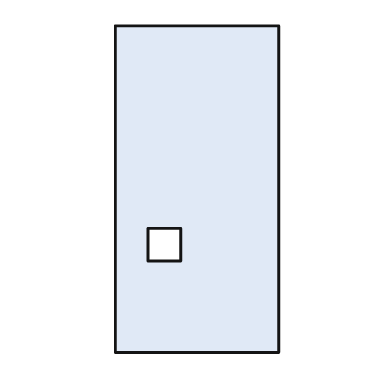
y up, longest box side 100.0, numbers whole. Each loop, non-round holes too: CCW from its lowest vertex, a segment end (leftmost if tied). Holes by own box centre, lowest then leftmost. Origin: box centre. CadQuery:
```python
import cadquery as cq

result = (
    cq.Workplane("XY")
    .moveTo(-25.0, -50.0)
    .lineTo(25.0, -50.0)
    .lineTo(25.0, 50.0)
    .lineTo(-25.0, 50.0)
    .close()
    .moveTo(-15.0, -22.0)
    .lineTo(-5.0, -22.0)
    .lineTo(-5.0, -12.0)
    .lineTo(-15.0, -12.0)
    .close()
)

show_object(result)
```